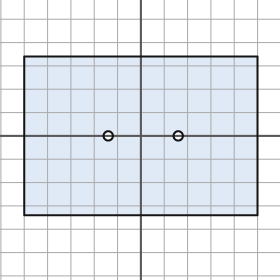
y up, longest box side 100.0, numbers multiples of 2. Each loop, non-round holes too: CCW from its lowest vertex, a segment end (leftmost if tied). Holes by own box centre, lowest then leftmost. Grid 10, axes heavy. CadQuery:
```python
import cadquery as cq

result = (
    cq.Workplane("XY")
    .moveTo(-50.0, -34.0)
    .lineTo(50.0, -34.0)
    .lineTo(50.0, 34.0)
    .lineTo(-50.0, 34.0)
    .close()
    .moveTo(-14.0, 0.0)
    .circle(2.0)
    .moveTo(16.0, 0.0)
    .circle(2.0)
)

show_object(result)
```